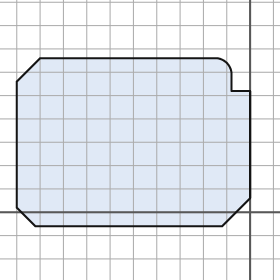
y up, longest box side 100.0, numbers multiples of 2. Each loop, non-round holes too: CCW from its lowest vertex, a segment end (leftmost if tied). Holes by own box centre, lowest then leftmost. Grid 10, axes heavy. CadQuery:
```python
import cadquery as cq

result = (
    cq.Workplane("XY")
    .moveTo(-92.0, -6.0)
    .lineTo(-12.0, -6.0)
    .lineTo(0.0, 6.0)
    .lineTo(0.0, 52.0)
    .lineTo(-8.0, 52.0)
    .lineTo(-8.0, 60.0)
    .threePointArc((-10.0, 64.0), (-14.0, 66.0))
    .lineTo(-90.0, 66.0)
    .lineTo(-100.0, 56.0)
    .lineTo(-100.0, 2.0)
    .close()
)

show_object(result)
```